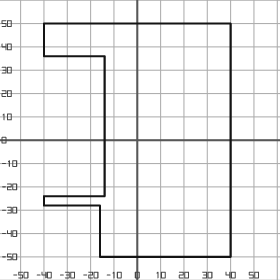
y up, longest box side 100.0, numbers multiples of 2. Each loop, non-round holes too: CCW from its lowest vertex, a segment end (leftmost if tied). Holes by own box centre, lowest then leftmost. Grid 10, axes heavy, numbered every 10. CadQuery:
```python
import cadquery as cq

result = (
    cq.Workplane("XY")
    .moveTo(-16.0, -50.0)
    .lineTo(40.0, -50.0)
    .lineTo(40.0, 50.0)
    .lineTo(-40.0, 50.0)
    .lineTo(-40.0, 36.0)
    .lineTo(-14.0, 36.0)
    .lineTo(-14.0, -24.0)
    .lineTo(-40.0, -24.0)
    .lineTo(-40.0, -28.0)
    .lineTo(-16.0, -28.0)
    .close()
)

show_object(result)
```